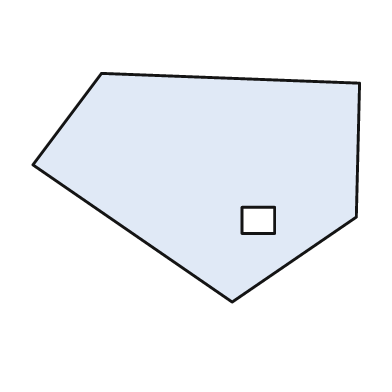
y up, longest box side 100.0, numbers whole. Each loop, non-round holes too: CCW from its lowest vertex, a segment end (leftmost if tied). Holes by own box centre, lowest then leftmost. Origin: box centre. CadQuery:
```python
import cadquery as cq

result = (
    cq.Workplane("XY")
    .moveTo(11.0, -35.0)
    .lineTo(49.0, -9.0)
    .lineTo(50.0, 32.0)
    .lineTo(-29.0, 35.0)
    .lineTo(-50.0, 7.0)
    .close()
    .moveTo(14.0, -14.0)
    .lineTo(24.0, -14.0)
    .lineTo(24.0, -6.0)
    .lineTo(14.0, -6.0)
    .close()
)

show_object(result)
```